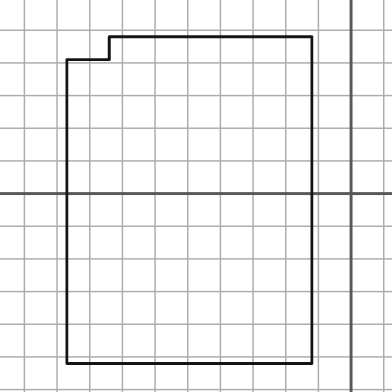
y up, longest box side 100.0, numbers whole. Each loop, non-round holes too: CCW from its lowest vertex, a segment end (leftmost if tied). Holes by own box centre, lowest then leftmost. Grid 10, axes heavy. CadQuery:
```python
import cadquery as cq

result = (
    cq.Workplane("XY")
    .moveTo(-87.0, -52.0)
    .lineTo(-12.0, -52.0)
    .lineTo(-12.0, 48.0)
    .lineTo(-74.0, 48.0)
    .lineTo(-74.0, 41.0)
    .lineTo(-87.0, 41.0)
    .close()
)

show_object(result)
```